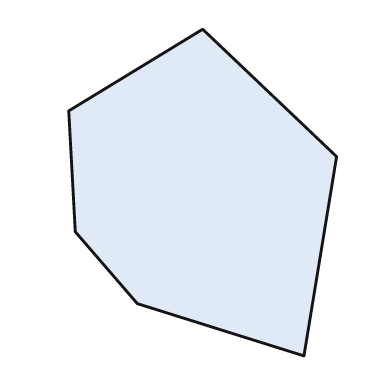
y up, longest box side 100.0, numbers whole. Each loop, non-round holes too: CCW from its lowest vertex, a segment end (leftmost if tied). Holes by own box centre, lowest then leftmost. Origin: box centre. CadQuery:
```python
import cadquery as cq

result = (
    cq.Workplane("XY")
    .moveTo(31.0, -50.0)
    .lineTo(41.0, 11.0)
    .lineTo(0.0, 50.0)
    .lineTo(-41.0, 25.0)
    .lineTo(-39.0, -12.0)
    .lineTo(-20.0, -34.0)
    .close()
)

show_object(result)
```